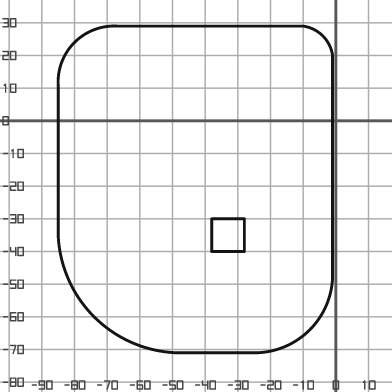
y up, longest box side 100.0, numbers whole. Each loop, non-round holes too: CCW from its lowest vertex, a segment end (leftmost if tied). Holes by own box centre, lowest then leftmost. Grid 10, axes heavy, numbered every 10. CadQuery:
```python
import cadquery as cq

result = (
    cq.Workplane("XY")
    .moveTo(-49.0, -71.0)
    .lineTo(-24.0, -71.0)
    .threePointArc((-8.0, -64.0), (-1.0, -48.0))
    .lineTo(-1.0, 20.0)
    .threePointArc((-4.0, 26.0), (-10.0, 29.0))
    .lineTo(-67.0, 29.0)
    .threePointArc((-80.0, 24.0), (-85.0, 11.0))
    .lineTo(-85.0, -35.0)
    .threePointArc((-74.0, -60.0), (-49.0, -71.0))
    .close()
    .moveTo(-38.0, -40.0)
    .lineTo(-28.0, -40.0)
    .lineTo(-28.0, -30.0)
    .lineTo(-38.0, -30.0)
    .close()
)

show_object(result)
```